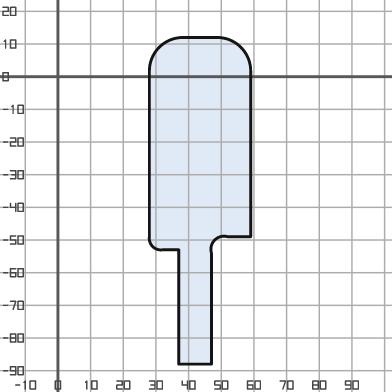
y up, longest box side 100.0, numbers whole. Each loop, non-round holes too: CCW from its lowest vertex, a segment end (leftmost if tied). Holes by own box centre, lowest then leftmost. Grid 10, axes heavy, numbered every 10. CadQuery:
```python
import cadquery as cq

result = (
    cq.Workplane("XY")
    .moveTo(37.0, -88.0)
    .lineTo(47.0, -88.0)
    .lineTo(47.0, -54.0)
    .threePointArc((48.0, -50.0), (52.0, -49.0))
    .lineTo(59.0, -49.0)
    .lineTo(59.0, 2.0)
    .threePointArc((56.0, 9.0), (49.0, 12.0))
    .lineTo(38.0, 12.0)
    .threePointArc((31.0, 9.0), (28.0, 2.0))
    .lineTo(28.0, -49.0)
    .threePointArc((29.0, -52.0), (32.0, -53.0))
    .lineTo(37.0, -53.0)
    .close()
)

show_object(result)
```